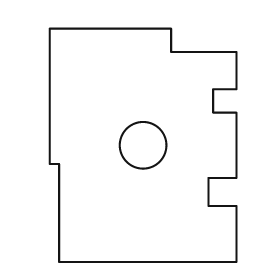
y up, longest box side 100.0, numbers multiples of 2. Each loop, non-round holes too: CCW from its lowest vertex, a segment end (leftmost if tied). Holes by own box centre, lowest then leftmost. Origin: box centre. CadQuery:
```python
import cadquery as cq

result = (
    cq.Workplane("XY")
    .moveTo(-36.0, -50.0)
    .lineTo(40.0, -50.0)
    .lineTo(40.0, -26.0)
    .lineTo(28.0, -26.0)
    .lineTo(28.0, -14.0)
    .lineTo(40.0, -14.0)
    .lineTo(40.0, 14.0)
    .lineTo(30.0, 14.0)
    .lineTo(30.0, 24.0)
    .lineTo(40.0, 24.0)
    .lineTo(40.0, 40.0)
    .lineTo(12.0, 40.0)
    .lineTo(12.0, 50.0)
    .lineTo(-40.0, 50.0)
    .lineTo(-40.0, -8.0)
    .lineTo(-36.0, -8.0)
    .close()
    .moveTo(0.0, 0.0)
    .circle(10.0)
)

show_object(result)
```